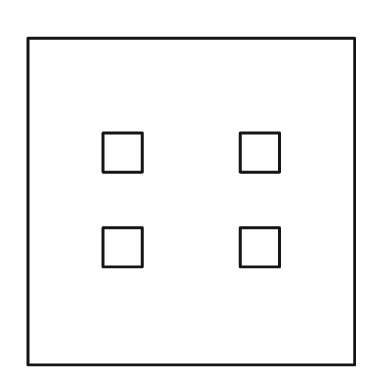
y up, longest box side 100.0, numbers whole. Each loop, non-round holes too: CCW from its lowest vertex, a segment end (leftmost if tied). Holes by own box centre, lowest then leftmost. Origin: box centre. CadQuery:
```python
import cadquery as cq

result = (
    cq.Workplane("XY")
    .moveTo(-50.0, -50.0)
    .lineTo(50.0, -50.0)
    .lineTo(50.0, 50.0)
    .lineTo(-50.0, 50.0)
    .close()
    .moveTo(-27.0, -20.0)
    .lineTo(-15.0, -20.0)
    .lineTo(-15.0, -8.0)
    .lineTo(-27.0, -8.0)
    .close()
    .moveTo(15.0, -20.0)
    .lineTo(27.0, -20.0)
    .lineTo(27.0, -8.0)
    .lineTo(15.0, -8.0)
    .close()
    .moveTo(-27.0, 9.0)
    .lineTo(-15.0, 9.0)
    .lineTo(-15.0, 21.0)
    .lineTo(-27.0, 21.0)
    .close()
    .moveTo(15.0, 9.0)
    .lineTo(27.0, 9.0)
    .lineTo(27.0, 21.0)
    .lineTo(15.0, 21.0)
    .close()
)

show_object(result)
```